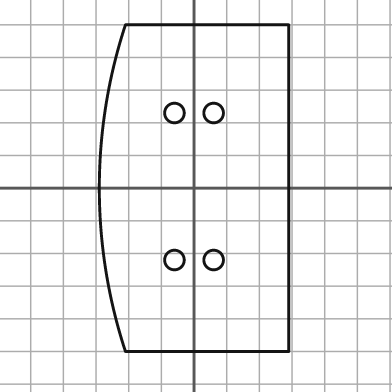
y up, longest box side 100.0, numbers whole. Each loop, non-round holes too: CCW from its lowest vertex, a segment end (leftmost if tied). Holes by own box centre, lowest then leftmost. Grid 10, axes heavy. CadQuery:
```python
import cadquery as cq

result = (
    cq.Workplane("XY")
    .moveTo(-21.0, -50.0)
    .lineTo(29.0, -50.0)
    .lineTo(29.0, 50.0)
    .lineTo(-21.0, 50.0)
    .threePointArc((-29.0, 0.0), (-21.0, -50.0))
    .close()
    .moveTo(-6.0, -22.0)
    .circle(3.0)
    .moveTo(6.0, -22.0)
    .circle(3.0)
    .moveTo(-6.0, 23.0)
    .circle(3.0)
    .moveTo(6.0, 23.0)
    .circle(3.0)
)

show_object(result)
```